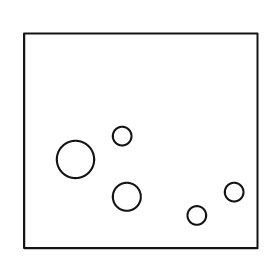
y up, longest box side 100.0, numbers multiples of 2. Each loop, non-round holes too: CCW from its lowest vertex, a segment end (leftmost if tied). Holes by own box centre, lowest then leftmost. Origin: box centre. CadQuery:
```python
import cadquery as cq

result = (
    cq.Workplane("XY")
    .moveTo(-50.0, -46.0)
    .lineTo(50.0, -46.0)
    .lineTo(50.0, 46.0)
    .lineTo(-50.0, 46.0)
    .close()
    .moveTo(24.0, -32.0)
    .circle(4.0)
    .moveTo(-6.0, -24.0)
    .circle(6.0)
    .moveTo(40.0, -22.0)
    .circle(4.0)
    .moveTo(-28.0, -8.0)
    .circle(8.0)
    .moveTo(-8.0, 2.0)
    .circle(4.0)
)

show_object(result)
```